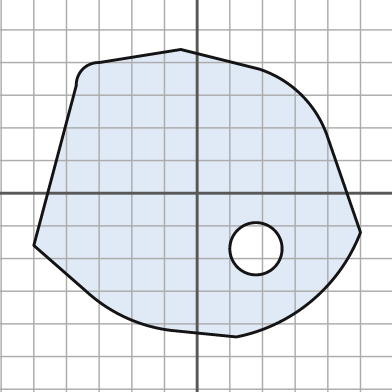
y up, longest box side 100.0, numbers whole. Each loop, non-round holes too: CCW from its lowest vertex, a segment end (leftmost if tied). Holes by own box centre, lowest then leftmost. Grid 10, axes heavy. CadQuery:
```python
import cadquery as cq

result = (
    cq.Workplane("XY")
    .moveTo(12.0, -44.0)
    .threePointArc((35.0, -33.0), (50.0, -12.0))
    .lineTo(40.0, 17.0)
    .threePointArc((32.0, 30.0), (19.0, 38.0))
    .lineTo(-5.0, 44.0)
    .lineTo(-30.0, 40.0)
    .threePointArc((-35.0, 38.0), (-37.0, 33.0))
    .lineTo(-50.0, -16.0)
    .lineTo(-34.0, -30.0)
    .threePointArc((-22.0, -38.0), (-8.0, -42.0))
    .close()
    .moveTo(18.0, -17.0)
    .circle(8.0)
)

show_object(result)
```